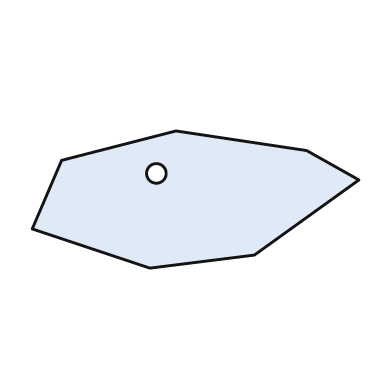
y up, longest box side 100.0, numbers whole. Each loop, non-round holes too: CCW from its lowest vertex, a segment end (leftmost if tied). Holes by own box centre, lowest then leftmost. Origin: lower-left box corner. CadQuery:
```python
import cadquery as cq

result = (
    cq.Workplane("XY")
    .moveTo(36.0, 0.0)
    .lineTo(68.0, 4.0)
    .lineTo(100.0, 27.0)
    .lineTo(84.0, 36.0)
    .lineTo(44.0, 42.0)
    .lineTo(9.0, 33.0)
    .lineTo(0.0, 12.0)
    .close()
    .moveTo(38.0, 29.0)
    .circle(3.0)
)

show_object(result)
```